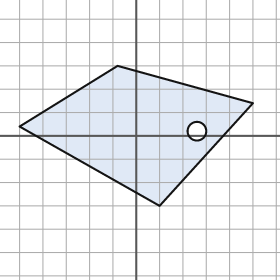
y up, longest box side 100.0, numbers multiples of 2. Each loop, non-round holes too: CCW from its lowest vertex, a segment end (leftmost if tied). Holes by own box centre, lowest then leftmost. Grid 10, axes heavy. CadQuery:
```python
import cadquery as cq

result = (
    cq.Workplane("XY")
    .moveTo(10.0, -30.0)
    .lineTo(50.0, 14.0)
    .lineTo(-8.0, 30.0)
    .lineTo(-50.0, 4.0)
    .close()
    .moveTo(26.0, 2.0)
    .circle(4.0)
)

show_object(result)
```